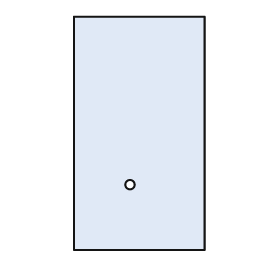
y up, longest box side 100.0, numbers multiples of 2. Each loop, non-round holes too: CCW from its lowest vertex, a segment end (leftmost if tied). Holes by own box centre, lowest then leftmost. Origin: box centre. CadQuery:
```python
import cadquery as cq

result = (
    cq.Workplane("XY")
    .moveTo(-28.0, -50.0)
    .lineTo(28.0, -50.0)
    .lineTo(28.0, 50.0)
    .lineTo(-28.0, 50.0)
    .close()
    .moveTo(-4.0, -22.0)
    .circle(2.0)
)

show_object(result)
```